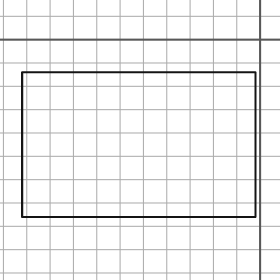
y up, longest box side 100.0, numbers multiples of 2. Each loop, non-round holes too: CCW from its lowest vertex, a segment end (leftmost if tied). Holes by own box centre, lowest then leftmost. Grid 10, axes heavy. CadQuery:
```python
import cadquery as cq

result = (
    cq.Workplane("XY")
    .moveTo(-102.0, -76.0)
    .lineTo(-2.0, -76.0)
    .lineTo(-2.0, -14.0)
    .lineTo(-102.0, -14.0)
    .close()
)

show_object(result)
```